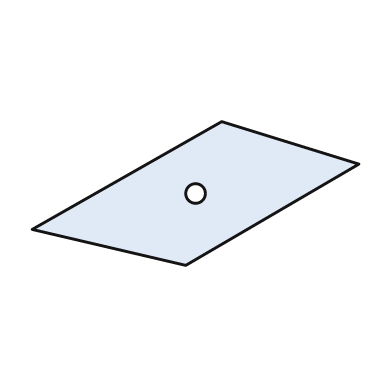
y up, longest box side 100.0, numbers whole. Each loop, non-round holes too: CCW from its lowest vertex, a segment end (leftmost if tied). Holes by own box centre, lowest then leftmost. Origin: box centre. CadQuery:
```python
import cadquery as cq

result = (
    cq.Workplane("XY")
    .moveTo(-3.0, -22.0)
    .lineTo(50.0, 9.0)
    .lineTo(8.0, 22.0)
    .lineTo(-50.0, -11.0)
    .close()
    .moveTo(0.0, 0.0)
    .circle(3.0)
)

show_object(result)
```